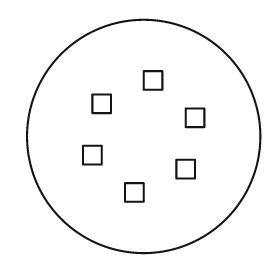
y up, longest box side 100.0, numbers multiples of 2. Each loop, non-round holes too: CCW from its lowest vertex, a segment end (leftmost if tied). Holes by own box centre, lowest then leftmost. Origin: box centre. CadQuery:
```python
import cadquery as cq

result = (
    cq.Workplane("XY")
    .moveTo(0.0, 0.0)
    .circle(50.0)
    .moveTo(-8.0, -28.0)
    .lineTo(0.0, -28.0)
    .lineTo(0.0, -20.0)
    .lineTo(-8.0, -20.0)
    .close()
    .moveTo(14.0, -18.0)
    .lineTo(22.0, -18.0)
    .lineTo(22.0, -10.0)
    .lineTo(14.0, -10.0)
    .close()
    .moveTo(-26.0, -12.0)
    .lineTo(-18.0, -12.0)
    .lineTo(-18.0, -4.0)
    .lineTo(-26.0, -4.0)
    .close()
    .moveTo(18.0, 4.0)
    .lineTo(26.0, 4.0)
    .lineTo(26.0, 12.0)
    .lineTo(18.0, 12.0)
    .close()
    .moveTo(-22.0, 10.0)
    .lineTo(-14.0, 10.0)
    .lineTo(-14.0, 18.0)
    .lineTo(-22.0, 18.0)
    .close()
    .moveTo(0.0, 20.0)
    .lineTo(8.0, 20.0)
    .lineTo(8.0, 28.0)
    .lineTo(0.0, 28.0)
    .close()
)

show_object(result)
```